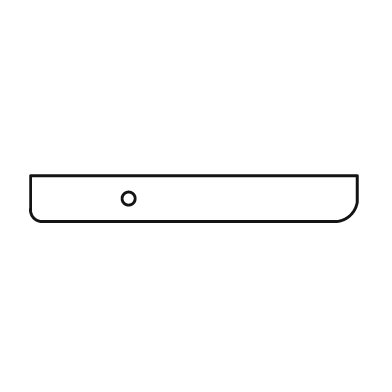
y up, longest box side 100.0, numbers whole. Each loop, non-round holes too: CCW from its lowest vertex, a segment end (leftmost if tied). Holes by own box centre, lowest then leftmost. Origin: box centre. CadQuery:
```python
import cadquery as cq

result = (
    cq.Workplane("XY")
    .moveTo(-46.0, -7.0)
    .lineTo(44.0, -7.0)
    .threePointArc((48.0, -5.0), (50.0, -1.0))
    .lineTo(50.0, 7.0)
    .lineTo(-50.0, 7.0)
    .lineTo(-50.0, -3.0)
    .threePointArc((-49.0, -6.0), (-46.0, -7.0))
    .close()
    .moveTo(-20.0, 0.0)
    .circle(2.0)
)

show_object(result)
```